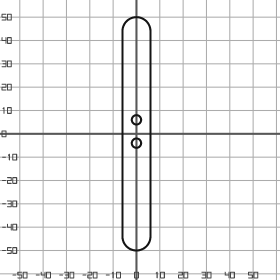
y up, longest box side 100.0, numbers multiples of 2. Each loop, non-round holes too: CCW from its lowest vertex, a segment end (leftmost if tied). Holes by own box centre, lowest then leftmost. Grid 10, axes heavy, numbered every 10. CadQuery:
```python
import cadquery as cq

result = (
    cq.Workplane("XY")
    .moveTo(-6.0, -44.0)
    .threePointArc((0.0, -50.0), (6.0, -44.0))
    .lineTo(6.0, 44.0)
    .threePointArc((0.0, 50.0), (-6.0, 44.0))
    .close()
    .moveTo(0.0, -4.0)
    .circle(2.0)
    .moveTo(0.0, 6.0)
    .circle(2.0)
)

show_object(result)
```